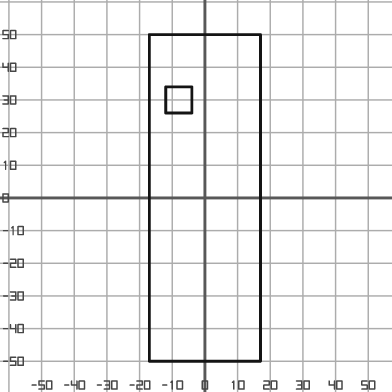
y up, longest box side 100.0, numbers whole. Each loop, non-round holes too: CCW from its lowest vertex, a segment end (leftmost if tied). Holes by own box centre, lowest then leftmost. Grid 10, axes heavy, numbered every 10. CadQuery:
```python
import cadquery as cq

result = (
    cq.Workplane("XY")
    .moveTo(-17.0, -50.0)
    .lineTo(17.0, -50.0)
    .lineTo(17.0, 50.0)
    .lineTo(-17.0, 50.0)
    .close()
    .moveTo(-12.0, 26.0)
    .lineTo(-4.0, 26.0)
    .lineTo(-4.0, 34.0)
    .lineTo(-12.0, 34.0)
    .close()
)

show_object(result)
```